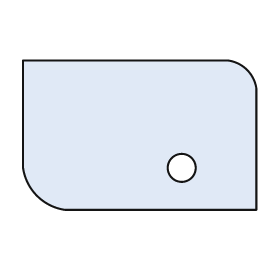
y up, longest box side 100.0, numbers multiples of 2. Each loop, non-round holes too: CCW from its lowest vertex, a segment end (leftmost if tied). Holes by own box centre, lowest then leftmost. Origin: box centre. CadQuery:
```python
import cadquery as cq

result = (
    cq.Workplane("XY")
    .moveTo(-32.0, -32.0)
    .lineTo(50.0, -32.0)
    .lineTo(50.0, 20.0)
    .threePointArc((46.0, 28.0), (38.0, 32.0))
    .lineTo(-50.0, 32.0)
    .lineTo(-50.0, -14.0)
    .threePointArc((-44.0, -26.0), (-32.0, -32.0))
    .close()
    .moveTo(18.0, -14.0)
    .circle(6.0)
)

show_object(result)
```